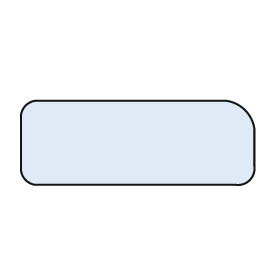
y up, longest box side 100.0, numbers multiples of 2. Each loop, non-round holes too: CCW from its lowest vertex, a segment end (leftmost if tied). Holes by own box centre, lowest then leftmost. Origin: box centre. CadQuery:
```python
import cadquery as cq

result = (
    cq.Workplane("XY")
    .moveTo(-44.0, -18.0)
    .lineTo(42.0, -18.0)
    .threePointArc((48.0, -16.0), (50.0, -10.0))
    .lineTo(50.0, 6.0)
    .threePointArc((46.0, 14.0), (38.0, 18.0))
    .lineTo(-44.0, 18.0)
    .threePointArc((-48.0, 16.0), (-50.0, 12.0))
    .lineTo(-50.0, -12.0)
    .threePointArc((-48.0, -16.0), (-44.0, -18.0))
    .close()
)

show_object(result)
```